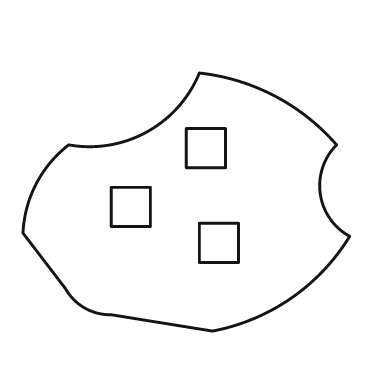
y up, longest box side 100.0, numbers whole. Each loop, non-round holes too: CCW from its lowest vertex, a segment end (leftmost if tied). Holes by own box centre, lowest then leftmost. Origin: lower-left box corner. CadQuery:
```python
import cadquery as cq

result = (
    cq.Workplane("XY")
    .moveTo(58.0, 0.0)
    .threePointArc((82.0, 10.0), (100.0, 29.0))
    .threePointArc((91.0, 42.0), (96.0, 57.0))
    .threePointArc((77.0, 72.0), (54.0, 79.0))
    .threePointArc((38.0, 61.0), (14.0, 57.0))
    .threePointArc((4.0, 45.0), (0.0, 30.0))
    .lineTo(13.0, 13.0)
    .threePointArc((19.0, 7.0), (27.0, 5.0))
    .close()
    .moveTo(54.0, 21.0)
    .lineTo(66.0, 21.0)
    .lineTo(66.0, 33.0)
    .lineTo(54.0, 33.0)
    .close()
    .moveTo(27.0, 32.0)
    .lineTo(39.0, 32.0)
    .lineTo(39.0, 44.0)
    .lineTo(27.0, 44.0)
    .close()
    .moveTo(50.0, 50.0)
    .lineTo(62.0, 50.0)
    .lineTo(62.0, 62.0)
    .lineTo(50.0, 62.0)
    .close()
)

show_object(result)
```